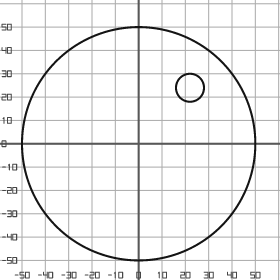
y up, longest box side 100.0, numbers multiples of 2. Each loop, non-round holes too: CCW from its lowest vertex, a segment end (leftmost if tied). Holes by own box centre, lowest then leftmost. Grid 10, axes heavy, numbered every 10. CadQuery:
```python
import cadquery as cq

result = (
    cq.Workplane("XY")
    .moveTo(0.0, 0.0)
    .circle(50.0)
    .moveTo(22.0, 24.0)
    .circle(6.0)
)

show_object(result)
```